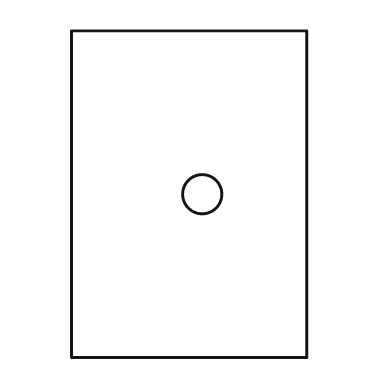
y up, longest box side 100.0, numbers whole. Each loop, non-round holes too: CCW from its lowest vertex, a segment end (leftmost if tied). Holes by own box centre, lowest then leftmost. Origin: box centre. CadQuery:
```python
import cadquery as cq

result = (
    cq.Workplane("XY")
    .moveTo(-36.0, -50.0)
    .lineTo(36.0, -50.0)
    .lineTo(36.0, 50.0)
    .lineTo(-36.0, 50.0)
    .close()
    .moveTo(4.0, 0.0)
    .circle(6.0)
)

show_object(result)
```